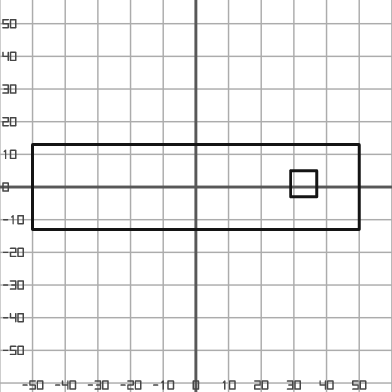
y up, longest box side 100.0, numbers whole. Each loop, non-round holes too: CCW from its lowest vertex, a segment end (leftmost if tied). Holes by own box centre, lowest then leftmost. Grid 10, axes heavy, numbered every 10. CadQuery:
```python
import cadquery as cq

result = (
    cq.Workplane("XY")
    .moveTo(-50.0, -13.0)
    .lineTo(50.0, -13.0)
    .lineTo(50.0, 13.0)
    .lineTo(-50.0, 13.0)
    .close()
    .moveTo(29.0, -3.0)
    .lineTo(37.0, -3.0)
    .lineTo(37.0, 5.0)
    .lineTo(29.0, 5.0)
    .close()
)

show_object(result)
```